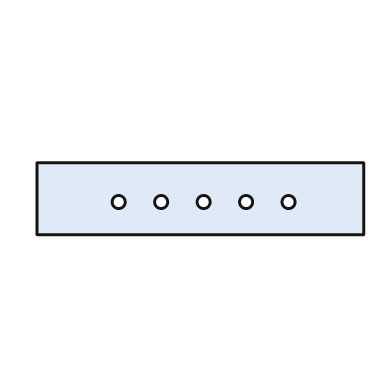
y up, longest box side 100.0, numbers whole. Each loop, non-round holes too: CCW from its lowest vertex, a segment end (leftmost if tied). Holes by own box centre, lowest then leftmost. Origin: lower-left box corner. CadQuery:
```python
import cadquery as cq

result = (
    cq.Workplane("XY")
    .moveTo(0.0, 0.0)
    .lineTo(100.0, 0.0)
    .lineTo(100.0, 22.0)
    .lineTo(0.0, 22.0)
    .close()
    .moveTo(25.0, 10.0)
    .circle(2.0)
    .moveTo(38.0, 10.0)
    .circle(2.0)
    .moveTo(51.0, 10.0)
    .circle(2.0)
    .moveTo(64.0, 10.0)
    .circle(2.0)
    .moveTo(77.0, 10.0)
    .circle(2.0)
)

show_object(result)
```